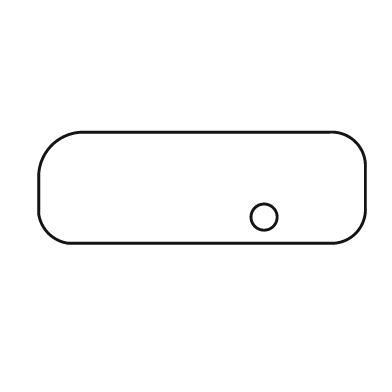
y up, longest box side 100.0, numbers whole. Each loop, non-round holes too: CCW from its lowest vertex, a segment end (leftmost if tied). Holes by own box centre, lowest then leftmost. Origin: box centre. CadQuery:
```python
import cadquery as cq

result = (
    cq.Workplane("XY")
    .moveTo(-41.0, -17.0)
    .lineTo(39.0, -17.0)
    .threePointArc((47.0, -14.0), (50.0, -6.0))
    .lineTo(50.0, 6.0)
    .threePointArc((47.0, 14.0), (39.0, 17.0))
    .lineTo(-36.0, 17.0)
    .threePointArc((-46.0, 13.0), (-50.0, 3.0))
    .lineTo(-50.0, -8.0)
    .threePointArc((-47.0, -14.0), (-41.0, -17.0))
    .close()
    .moveTo(19.0, -9.0)
    .circle(4.0)
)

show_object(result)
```